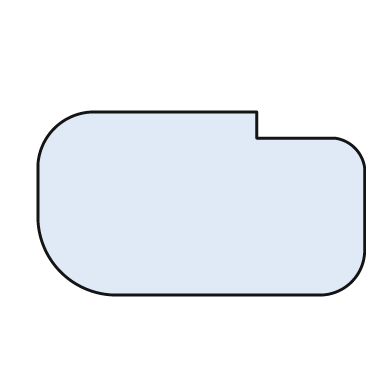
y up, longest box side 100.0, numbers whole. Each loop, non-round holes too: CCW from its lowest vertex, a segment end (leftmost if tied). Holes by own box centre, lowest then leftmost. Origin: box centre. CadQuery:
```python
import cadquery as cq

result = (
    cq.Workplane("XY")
    .moveTo(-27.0, -28.0)
    .lineTo(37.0, -28.0)
    .threePointArc((46.0, -24.0), (50.0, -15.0))
    .lineTo(50.0, 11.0)
    .threePointArc((47.0, 17.0), (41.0, 20.0))
    .lineTo(17.0, 20.0)
    .lineTo(17.0, 28.0)
    .lineTo(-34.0, 28.0)
    .threePointArc((-45.0, 23.0), (-50.0, 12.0))
    .lineTo(-50.0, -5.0)
    .threePointArc((-43.0, -21.0), (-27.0, -28.0))
    .close()
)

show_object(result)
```